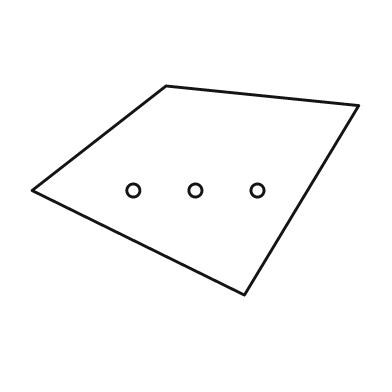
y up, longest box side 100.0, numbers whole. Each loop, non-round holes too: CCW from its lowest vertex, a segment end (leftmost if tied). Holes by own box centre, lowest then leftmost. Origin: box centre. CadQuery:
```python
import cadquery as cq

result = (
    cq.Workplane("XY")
    .moveTo(15.0, -32.0)
    .lineTo(50.0, 26.0)
    .lineTo(-9.0, 32.0)
    .lineTo(-50.0, 0.0)
    .close()
    .moveTo(-19.0, 0.0)
    .circle(2.0)
    .moveTo(0.0, 0.0)
    .circle(2.0)
    .moveTo(19.0, 0.0)
    .circle(2.0)
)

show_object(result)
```